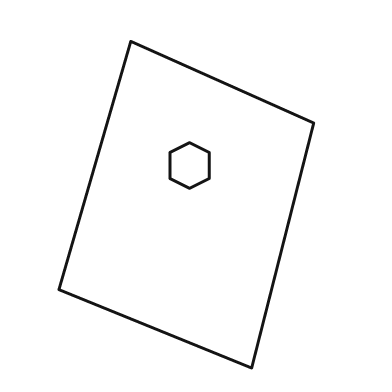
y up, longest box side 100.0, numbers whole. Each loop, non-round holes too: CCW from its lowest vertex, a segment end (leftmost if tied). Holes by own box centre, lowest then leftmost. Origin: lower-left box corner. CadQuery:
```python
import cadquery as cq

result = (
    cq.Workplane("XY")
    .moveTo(59.0, 0.0)
    .lineTo(78.0, 75.0)
    .lineTo(22.0, 100.0)
    .lineTo(0.0, 24.0)
    .close()
    .moveTo(40.0, 55.0)
    .lineTo(46.0, 58.0)
    .lineTo(46.0, 66.0)
    .lineTo(40.0, 69.0)
    .lineTo(34.0, 66.0)
    .lineTo(34.0, 58.0)
    .close()
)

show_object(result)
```